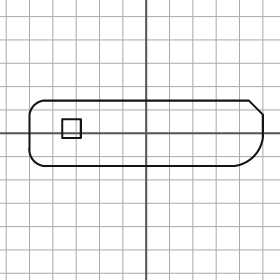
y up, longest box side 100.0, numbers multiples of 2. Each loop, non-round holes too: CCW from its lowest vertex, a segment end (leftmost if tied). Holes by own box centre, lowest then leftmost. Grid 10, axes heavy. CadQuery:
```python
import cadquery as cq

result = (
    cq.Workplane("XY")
    .moveTo(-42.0, -14.0)
    .lineTo(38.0, -14.0)
    .threePointArc((46.0, -10.0), (50.0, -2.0))
    .lineTo(50.0, 8.0)
    .lineTo(44.0, 14.0)
    .lineTo(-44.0, 14.0)
    .threePointArc((-48.0, 12.0), (-50.0, 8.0))
    .lineTo(-50.0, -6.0)
    .threePointArc((-48.0, -12.0), (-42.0, -14.0))
    .close()
    .moveTo(-36.0, -2.0)
    .lineTo(-28.0, -2.0)
    .lineTo(-28.0, 6.0)
    .lineTo(-36.0, 6.0)
    .close()
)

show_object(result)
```